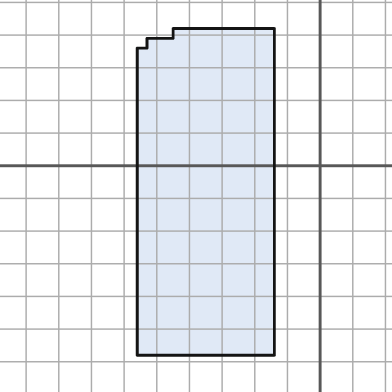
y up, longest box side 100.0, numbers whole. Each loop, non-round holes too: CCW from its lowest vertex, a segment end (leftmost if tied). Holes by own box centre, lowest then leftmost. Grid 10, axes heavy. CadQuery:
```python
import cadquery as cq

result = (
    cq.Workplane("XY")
    .moveTo(-56.0, -58.0)
    .lineTo(-14.0, -58.0)
    .lineTo(-14.0, 42.0)
    .lineTo(-45.0, 42.0)
    .lineTo(-45.0, 39.0)
    .lineTo(-53.0, 39.0)
    .lineTo(-53.0, 36.0)
    .lineTo(-56.0, 36.0)
    .close()
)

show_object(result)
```